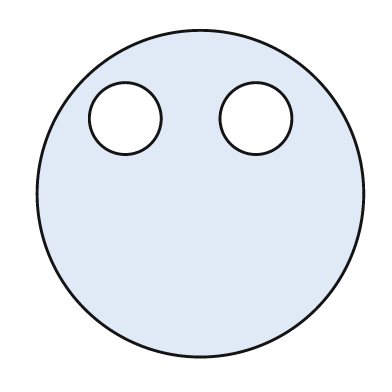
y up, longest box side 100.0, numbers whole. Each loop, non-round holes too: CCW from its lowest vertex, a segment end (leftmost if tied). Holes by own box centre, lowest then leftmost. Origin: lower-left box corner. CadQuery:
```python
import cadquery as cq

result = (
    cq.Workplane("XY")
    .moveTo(50.0, 50.0)
    .circle(50.0)
    .moveTo(27.0, 73.0)
    .circle(11.0)
    .moveTo(67.0, 73.0)
    .circle(11.0)
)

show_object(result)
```